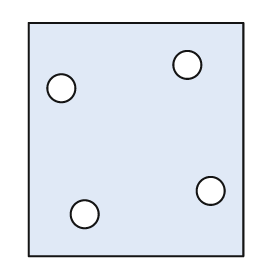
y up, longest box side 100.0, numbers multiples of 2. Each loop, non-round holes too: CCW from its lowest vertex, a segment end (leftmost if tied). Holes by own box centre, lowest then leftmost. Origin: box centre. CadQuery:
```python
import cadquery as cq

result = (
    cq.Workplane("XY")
    .moveTo(-46.0, -50.0)
    .lineTo(46.0, -50.0)
    .lineTo(46.0, 50.0)
    .lineTo(-46.0, 50.0)
    .close()
    .moveTo(-22.0, -32.0)
    .circle(6.0)
    .moveTo(32.0, -22.0)
    .circle(6.0)
    .moveTo(-32.0, 22.0)
    .circle(6.0)
    .moveTo(22.0, 32.0)
    .circle(6.0)
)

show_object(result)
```